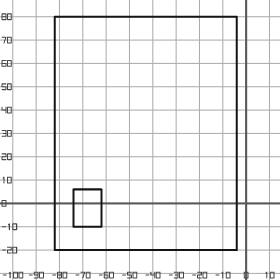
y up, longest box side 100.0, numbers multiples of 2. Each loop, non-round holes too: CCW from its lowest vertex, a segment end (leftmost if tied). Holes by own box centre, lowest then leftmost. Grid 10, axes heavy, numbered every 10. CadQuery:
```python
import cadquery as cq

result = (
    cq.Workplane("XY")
    .moveTo(-82.0, -20.0)
    .lineTo(-4.0, -20.0)
    .lineTo(-4.0, 80.0)
    .lineTo(-82.0, 80.0)
    .close()
    .moveTo(-74.0, -10.0)
    .lineTo(-62.0, -10.0)
    .lineTo(-62.0, 6.0)
    .lineTo(-74.0, 6.0)
    .close()
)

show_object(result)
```